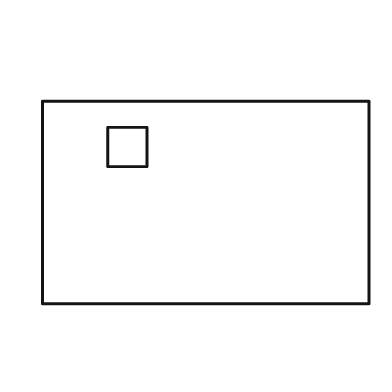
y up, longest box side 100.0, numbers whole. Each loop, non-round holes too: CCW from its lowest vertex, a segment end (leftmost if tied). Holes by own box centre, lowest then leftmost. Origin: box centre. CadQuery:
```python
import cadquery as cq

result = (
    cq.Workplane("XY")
    .moveTo(-50.0, -31.0)
    .lineTo(50.0, -31.0)
    .lineTo(50.0, 31.0)
    .lineTo(-50.0, 31.0)
    .close()
    .moveTo(-30.0, 11.0)
    .lineTo(-18.0, 11.0)
    .lineTo(-18.0, 23.0)
    .lineTo(-30.0, 23.0)
    .close()
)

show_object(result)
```